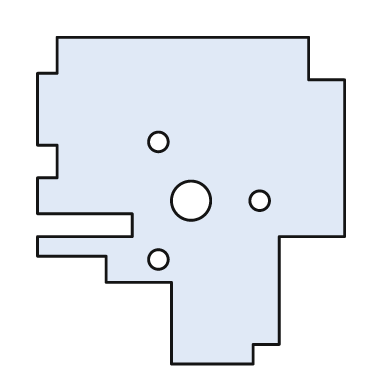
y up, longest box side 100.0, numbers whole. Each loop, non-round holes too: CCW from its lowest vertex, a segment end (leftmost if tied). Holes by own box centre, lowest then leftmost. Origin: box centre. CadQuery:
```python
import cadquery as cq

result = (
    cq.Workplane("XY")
    .moveTo(-6.0, -50.0)
    .lineTo(19.0, -50.0)
    .lineTo(19.0, -44.0)
    .lineTo(27.0, -44.0)
    .lineTo(27.0, -11.0)
    .lineTo(47.0, -11.0)
    .lineTo(47.0, 37.0)
    .lineTo(36.0, 37.0)
    .lineTo(36.0, 50.0)
    .lineTo(-41.0, 50.0)
    .lineTo(-41.0, 39.0)
    .lineTo(-47.0, 39.0)
    .lineTo(-47.0, 17.0)
    .lineTo(-41.0, 17.0)
    .lineTo(-41.0, 7.0)
    .lineTo(-47.0, 7.0)
    .lineTo(-47.0, -4.0)
    .lineTo(-18.0, -4.0)
    .lineTo(-18.0, -11.0)
    .lineTo(-47.0, -11.0)
    .lineTo(-47.0, -17.0)
    .lineTo(-26.0, -17.0)
    .lineTo(-26.0, -25.0)
    .lineTo(-6.0, -25.0)
    .close()
    .moveTo(-10.0, -18.0)
    .circle(3.0)
    .moveTo(0.0, 0.0)
    .circle(6.0)
    .moveTo(21.0, 0.0)
    .circle(3.0)
    .moveTo(-10.0, 18.0)
    .circle(3.0)
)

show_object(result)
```